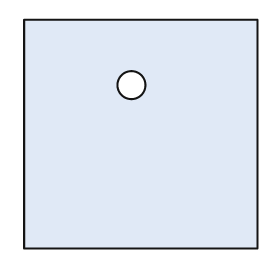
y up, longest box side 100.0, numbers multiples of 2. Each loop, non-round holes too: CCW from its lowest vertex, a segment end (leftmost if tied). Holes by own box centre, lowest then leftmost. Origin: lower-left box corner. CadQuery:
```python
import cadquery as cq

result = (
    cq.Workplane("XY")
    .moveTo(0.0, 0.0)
    .lineTo(100.0, 0.0)
    .lineTo(100.0, 98.0)
    .lineTo(0.0, 98.0)
    .close()
    .moveTo(46.0, 70.0)
    .circle(6.0)
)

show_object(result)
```